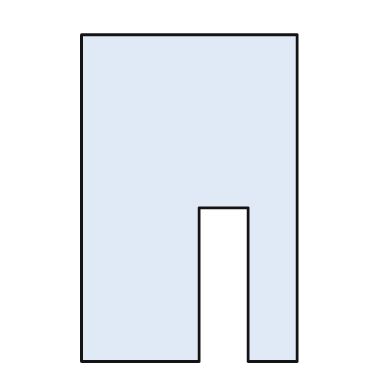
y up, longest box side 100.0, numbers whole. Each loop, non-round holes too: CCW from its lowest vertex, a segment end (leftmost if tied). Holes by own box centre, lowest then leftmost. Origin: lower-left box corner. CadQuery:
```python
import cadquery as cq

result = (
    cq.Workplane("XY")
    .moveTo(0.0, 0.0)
    .lineTo(36.0, 0.0)
    .lineTo(36.0, 47.0)
    .lineTo(51.0, 47.0)
    .lineTo(51.0, 0.0)
    .lineTo(66.0, 0.0)
    .lineTo(66.0, 100.0)
    .lineTo(0.0, 100.0)
    .close()
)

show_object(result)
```